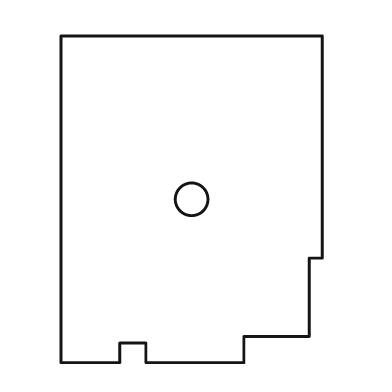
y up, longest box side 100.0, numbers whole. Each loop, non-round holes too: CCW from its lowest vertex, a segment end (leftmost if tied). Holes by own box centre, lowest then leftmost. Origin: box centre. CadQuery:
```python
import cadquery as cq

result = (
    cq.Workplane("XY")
    .moveTo(-40.0, -50.0)
    .lineTo(-22.0, -50.0)
    .lineTo(-22.0, -44.0)
    .lineTo(-14.0, -44.0)
    .lineTo(-14.0, -50.0)
    .lineTo(16.0, -50.0)
    .lineTo(16.0, -42.0)
    .lineTo(36.0, -42.0)
    .lineTo(36.0, -18.0)
    .lineTo(40.0, -18.0)
    .lineTo(40.0, 50.0)
    .lineTo(-40.0, 50.0)
    .close()
    .moveTo(0.0, 0.0)
    .circle(5.0)
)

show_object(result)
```